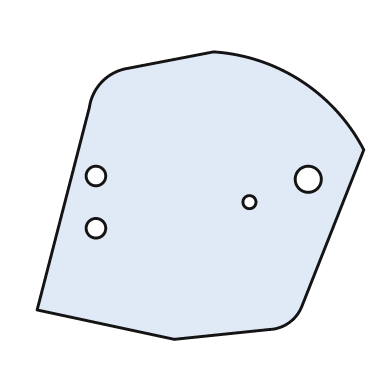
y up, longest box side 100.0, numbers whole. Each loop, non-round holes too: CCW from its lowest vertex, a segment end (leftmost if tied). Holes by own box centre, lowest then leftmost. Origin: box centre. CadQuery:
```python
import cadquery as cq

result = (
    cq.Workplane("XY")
    .moveTo(-8.0, -44.0)
    .lineTo(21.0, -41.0)
    .threePointArc((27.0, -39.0), (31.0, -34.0))
    .lineTo(50.0, 14.0)
    .threePointArc((31.0, 35.0), (4.0, 44.0))
    .lineTo(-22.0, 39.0)
    .threePointArc((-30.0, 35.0), (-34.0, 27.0))
    .lineTo(-50.0, -35.0)
    .close()
    .moveTo(-32.0, -10.0)
    .circle(3.0)
    .moveTo(15.0, -2.0)
    .circle(2.0)
    .moveTo(33.0, 5.0)
    .circle(4.0)
    .moveTo(-32.0, 6.0)
    .circle(3.0)
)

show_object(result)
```